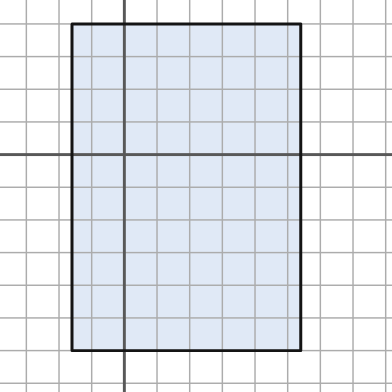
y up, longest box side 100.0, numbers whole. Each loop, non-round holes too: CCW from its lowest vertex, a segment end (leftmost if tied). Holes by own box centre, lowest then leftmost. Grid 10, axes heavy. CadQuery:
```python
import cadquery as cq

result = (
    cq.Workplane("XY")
    .moveTo(-16.0, -60.0)
    .lineTo(54.0, -60.0)
    .lineTo(54.0, 40.0)
    .lineTo(-16.0, 40.0)
    .close()
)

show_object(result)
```